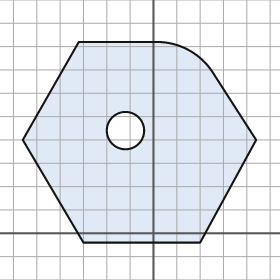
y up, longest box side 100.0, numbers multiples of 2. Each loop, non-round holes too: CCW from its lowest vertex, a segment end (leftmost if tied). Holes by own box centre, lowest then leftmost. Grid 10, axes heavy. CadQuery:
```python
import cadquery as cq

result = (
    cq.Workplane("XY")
    .moveTo(-30.0, -4.0)
    .lineTo(20.0, -4.0)
    .lineTo(44.0, 40.0)
    .lineTo(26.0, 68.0)
    .threePointArc((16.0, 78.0), (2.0, 82.0))
    .lineTo(-32.0, 82.0)
    .lineTo(-56.0, 40.0)
    .close()
    .moveTo(-12.0, 44.0)
    .circle(8.0)
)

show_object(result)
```